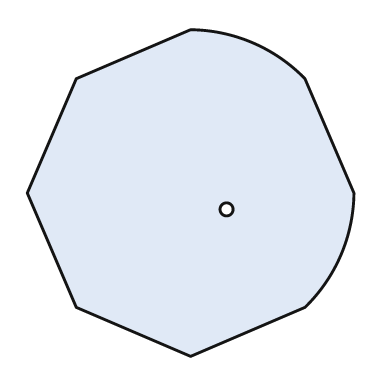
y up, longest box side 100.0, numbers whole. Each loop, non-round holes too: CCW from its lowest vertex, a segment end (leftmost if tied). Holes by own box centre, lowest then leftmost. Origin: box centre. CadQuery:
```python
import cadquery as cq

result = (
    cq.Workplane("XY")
    .moveTo(0.0, -50.0)
    .lineTo(35.0, -35.0)
    .threePointArc((46.0, -19.0), (50.0, 0.0))
    .lineTo(35.0, 35.0)
    .threePointArc((19.0, 46.0), (0.0, 50.0))
    .lineTo(-35.0, 35.0)
    .lineTo(-50.0, 0.0)
    .lineTo(-35.0, -35.0)
    .close()
    .moveTo(11.0, -5.0)
    .circle(2.0)
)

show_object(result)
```